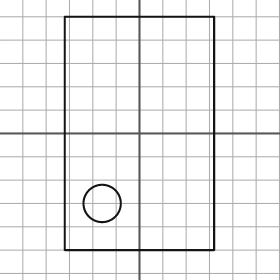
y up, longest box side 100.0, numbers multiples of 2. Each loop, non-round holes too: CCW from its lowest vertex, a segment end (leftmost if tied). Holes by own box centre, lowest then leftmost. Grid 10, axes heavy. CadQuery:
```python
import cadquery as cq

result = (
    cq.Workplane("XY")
    .moveTo(-32.0, -50.0)
    .lineTo(32.0, -50.0)
    .lineTo(32.0, 50.0)
    .lineTo(-32.0, 50.0)
    .close()
    .moveTo(-16.0, -30.0)
    .circle(8.0)
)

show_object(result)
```